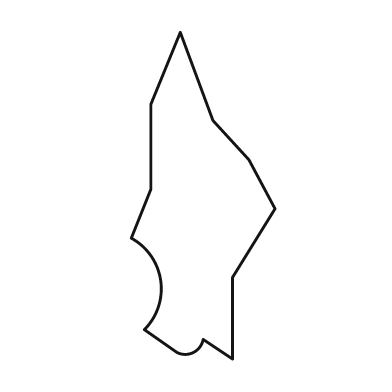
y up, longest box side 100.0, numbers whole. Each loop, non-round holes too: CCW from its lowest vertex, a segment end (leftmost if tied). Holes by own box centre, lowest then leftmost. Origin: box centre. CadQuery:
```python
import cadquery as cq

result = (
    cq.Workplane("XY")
    .moveTo(9.0, -50.0)
    .lineTo(9.0, -25.0)
    .lineTo(22.0, -4.0)
    .lineTo(14.0, 11.0)
    .lineTo(3.0, 23.0)
    .lineTo(-7.0, 50.0)
    .lineTo(-16.0, 28.0)
    .lineTo(-16.0, 2.0)
    .lineTo(-22.0, -13.0)
    .threePointArc((-13.0, -26.0), (-18.0, -41.0))
    .lineTo(-8.0, -48.0)
    .threePointArc((-3.0, -48.0), (0.0, -44.0))
    .close()
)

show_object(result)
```